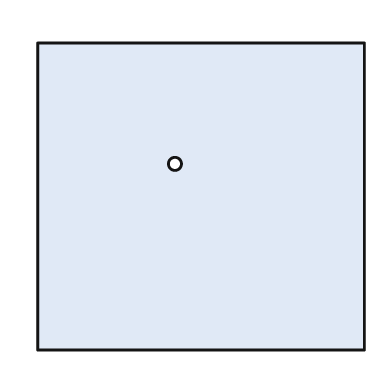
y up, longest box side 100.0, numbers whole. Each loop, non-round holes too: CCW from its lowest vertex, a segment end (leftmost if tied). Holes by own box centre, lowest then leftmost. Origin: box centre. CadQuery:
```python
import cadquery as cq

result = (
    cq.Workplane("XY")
    .moveTo(-50.0, -47.0)
    .lineTo(50.0, -47.0)
    .lineTo(50.0, 47.0)
    .lineTo(-50.0, 47.0)
    .close()
    .moveTo(-8.0, 10.0)
    .circle(2.0)
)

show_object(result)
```